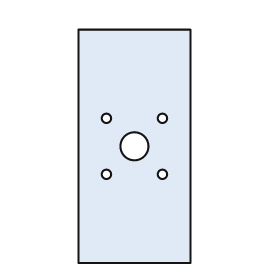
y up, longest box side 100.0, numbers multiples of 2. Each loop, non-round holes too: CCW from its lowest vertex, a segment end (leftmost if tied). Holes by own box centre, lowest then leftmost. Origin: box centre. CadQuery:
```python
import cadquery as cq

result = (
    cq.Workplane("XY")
    .moveTo(-24.0, -50.0)
    .lineTo(24.0, -50.0)
    .lineTo(24.0, 50.0)
    .lineTo(-24.0, 50.0)
    .close()
    .moveTo(-12.0, -12.0)
    .circle(2.0)
    .moveTo(12.0, -12.0)
    .circle(2.0)
    .moveTo(0.0, 0.0)
    .circle(6.0)
    .moveTo(-12.0, 12.0)
    .circle(2.0)
    .moveTo(12.0, 12.0)
    .circle(2.0)
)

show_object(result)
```